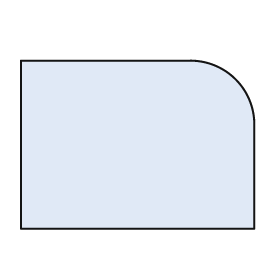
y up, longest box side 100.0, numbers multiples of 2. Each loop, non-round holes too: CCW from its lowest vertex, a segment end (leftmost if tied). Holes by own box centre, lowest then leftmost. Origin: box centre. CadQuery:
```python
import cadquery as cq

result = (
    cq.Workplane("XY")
    .moveTo(-50.0, -36.0)
    .lineTo(50.0, -36.0)
    .lineTo(50.0, 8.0)
    .threePointArc((42.0, 28.0), (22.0, 36.0))
    .lineTo(-50.0, 36.0)
    .close()
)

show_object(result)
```